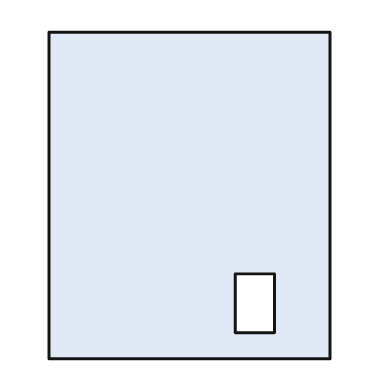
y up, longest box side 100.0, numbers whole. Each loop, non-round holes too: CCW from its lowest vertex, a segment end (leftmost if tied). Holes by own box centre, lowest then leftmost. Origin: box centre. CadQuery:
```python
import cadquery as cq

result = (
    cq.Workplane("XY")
    .moveTo(-43.0, -50.0)
    .lineTo(43.0, -50.0)
    .lineTo(43.0, 50.0)
    .lineTo(-43.0, 50.0)
    .close()
    .moveTo(14.0, -42.0)
    .lineTo(26.0, -42.0)
    .lineTo(26.0, -24.0)
    .lineTo(14.0, -24.0)
    .close()
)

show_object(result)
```